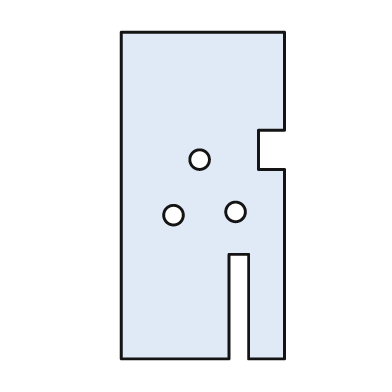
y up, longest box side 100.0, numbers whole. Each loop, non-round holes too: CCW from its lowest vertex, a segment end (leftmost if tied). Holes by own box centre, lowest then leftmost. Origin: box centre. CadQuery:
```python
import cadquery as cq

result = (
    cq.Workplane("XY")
    .moveTo(-25.0, -50.0)
    .lineTo(8.0, -50.0)
    .lineTo(8.0, -18.0)
    .lineTo(14.0, -18.0)
    .lineTo(14.0, -50.0)
    .lineTo(25.0, -50.0)
    .lineTo(25.0, 8.0)
    .lineTo(17.0, 8.0)
    .lineTo(17.0, 20.0)
    .lineTo(25.0, 20.0)
    .lineTo(25.0, 50.0)
    .lineTo(-25.0, 50.0)
    .close()
    .moveTo(-9.0, -6.0)
    .circle(3.0)
    .moveTo(10.0, -5.0)
    .circle(3.0)
    .moveTo(-1.0, 11.0)
    .circle(3.0)
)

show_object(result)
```